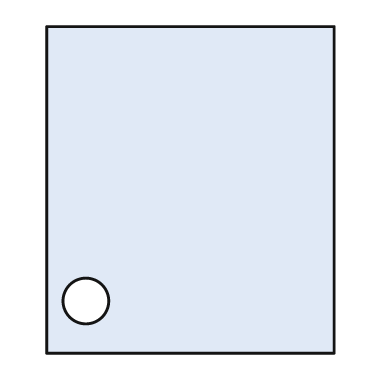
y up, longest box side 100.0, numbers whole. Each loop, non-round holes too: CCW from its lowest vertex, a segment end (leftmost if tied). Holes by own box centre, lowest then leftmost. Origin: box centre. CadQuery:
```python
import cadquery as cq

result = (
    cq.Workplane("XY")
    .moveTo(-44.0, -50.0)
    .lineTo(44.0, -50.0)
    .lineTo(44.0, 50.0)
    .lineTo(-44.0, 50.0)
    .close()
    .moveTo(-32.0, -34.0)
    .circle(7.0)
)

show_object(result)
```